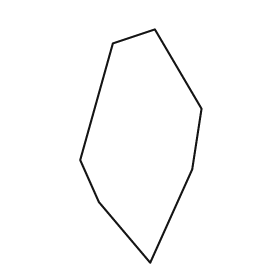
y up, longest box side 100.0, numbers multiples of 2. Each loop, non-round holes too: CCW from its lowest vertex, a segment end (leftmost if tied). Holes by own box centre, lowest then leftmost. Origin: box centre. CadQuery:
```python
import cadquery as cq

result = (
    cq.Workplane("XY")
    .moveTo(4.0, -50.0)
    .lineTo(22.0, -10.0)
    .lineTo(26.0, 16.0)
    .lineTo(6.0, 50.0)
    .lineTo(-12.0, 44.0)
    .lineTo(-26.0, -6.0)
    .lineTo(-18.0, -24.0)
    .close()
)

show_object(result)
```